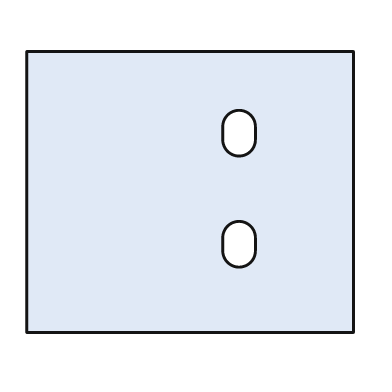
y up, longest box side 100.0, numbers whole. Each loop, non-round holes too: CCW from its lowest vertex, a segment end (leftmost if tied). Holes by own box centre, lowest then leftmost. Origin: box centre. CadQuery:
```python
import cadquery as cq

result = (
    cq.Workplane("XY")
    .moveTo(-50.0, -43.0)
    .lineTo(50.0, -43.0)
    .lineTo(50.0, 43.0)
    .lineTo(-50.0, 43.0)
    .close()
    .moveTo(10.0, -18.0)
    .threePointArc((15.0, -23.0), (20.0, -18.0))
    .lineTo(20.0, -14.0)
    .threePointArc((15.0, -9.0), (10.0, -14.0))
    .close()
    .moveTo(10.0, 16.0)
    .threePointArc((15.0, 11.0), (20.0, 16.0))
    .lineTo(20.0, 20.0)
    .threePointArc((15.0, 25.0), (10.0, 20.0))
    .close()
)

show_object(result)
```